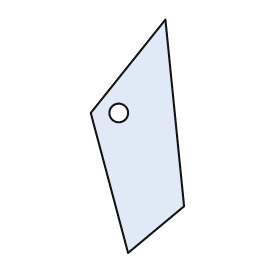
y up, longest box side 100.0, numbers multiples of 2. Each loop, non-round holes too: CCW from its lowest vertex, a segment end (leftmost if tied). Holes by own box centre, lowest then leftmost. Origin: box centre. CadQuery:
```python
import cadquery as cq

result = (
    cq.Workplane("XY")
    .moveTo(-4.0, -50.0)
    .lineTo(20.0, -30.0)
    .lineTo(12.0, 50.0)
    .lineTo(-20.0, 10.0)
    .close()
    .moveTo(-8.0, 10.0)
    .circle(4.0)
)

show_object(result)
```